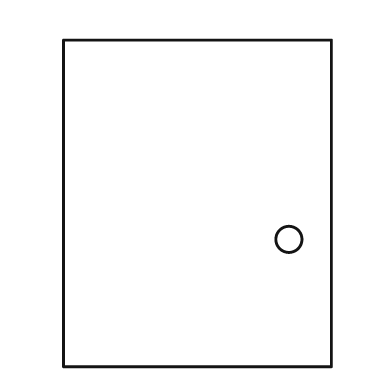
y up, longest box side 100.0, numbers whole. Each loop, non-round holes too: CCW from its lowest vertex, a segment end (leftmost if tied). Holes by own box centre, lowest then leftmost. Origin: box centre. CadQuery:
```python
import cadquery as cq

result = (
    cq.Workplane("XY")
    .moveTo(-41.0, -50.0)
    .lineTo(41.0, -50.0)
    .lineTo(41.0, 50.0)
    .lineTo(-41.0, 50.0)
    .close()
    .moveTo(28.0, -11.0)
    .circle(4.0)
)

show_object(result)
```